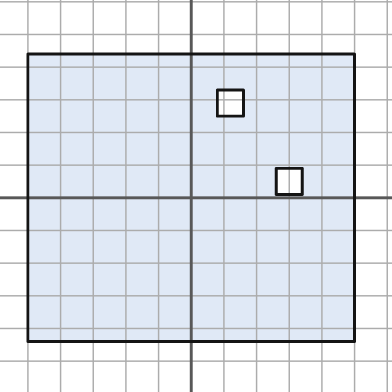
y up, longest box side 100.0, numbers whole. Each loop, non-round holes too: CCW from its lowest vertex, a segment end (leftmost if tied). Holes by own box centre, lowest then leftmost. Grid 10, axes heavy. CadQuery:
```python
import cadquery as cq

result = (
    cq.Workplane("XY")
    .moveTo(-50.0, -44.0)
    .lineTo(50.0, -44.0)
    .lineTo(50.0, 44.0)
    .lineTo(-50.0, 44.0)
    .close()
    .moveTo(26.0, 1.0)
    .lineTo(34.0, 1.0)
    .lineTo(34.0, 9.0)
    .lineTo(26.0, 9.0)
    .close()
    .moveTo(8.0, 25.0)
    .lineTo(16.0, 25.0)
    .lineTo(16.0, 33.0)
    .lineTo(8.0, 33.0)
    .close()
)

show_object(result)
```